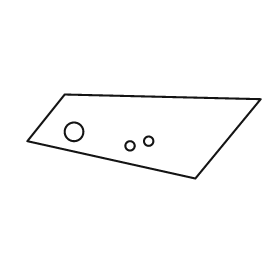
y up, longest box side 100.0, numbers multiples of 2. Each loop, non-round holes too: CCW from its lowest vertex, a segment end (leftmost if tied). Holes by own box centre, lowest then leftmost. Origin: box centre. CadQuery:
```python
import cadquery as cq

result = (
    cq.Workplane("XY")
    .moveTo(22.0, -18.0)
    .lineTo(50.0, 16.0)
    .lineTo(-34.0, 18.0)
    .lineTo(-50.0, -2.0)
    .close()
    .moveTo(-6.0, -4.0)
    .circle(2.0)
    .moveTo(2.0, -2.0)
    .circle(2.0)
    .moveTo(-30.0, 2.0)
    .circle(4.0)
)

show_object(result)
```